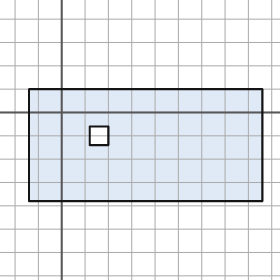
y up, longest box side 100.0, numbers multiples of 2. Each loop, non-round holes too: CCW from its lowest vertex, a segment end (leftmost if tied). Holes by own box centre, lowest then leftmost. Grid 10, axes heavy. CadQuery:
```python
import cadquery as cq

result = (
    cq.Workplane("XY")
    .moveTo(-14.0, -38.0)
    .lineTo(86.0, -38.0)
    .lineTo(86.0, 10.0)
    .lineTo(-14.0, 10.0)
    .close()
    .moveTo(12.0, -14.0)
    .lineTo(20.0, -14.0)
    .lineTo(20.0, -6.0)
    .lineTo(12.0, -6.0)
    .close()
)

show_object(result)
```